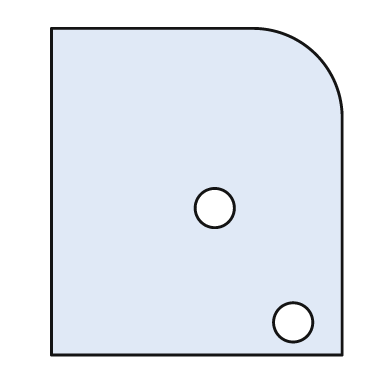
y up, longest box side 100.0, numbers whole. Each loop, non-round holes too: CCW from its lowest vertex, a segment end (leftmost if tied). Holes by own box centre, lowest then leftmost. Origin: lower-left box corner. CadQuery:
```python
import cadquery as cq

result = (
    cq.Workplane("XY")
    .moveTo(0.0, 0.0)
    .lineTo(89.0, 0.0)
    .lineTo(89.0, 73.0)
    .threePointArc((81.0, 92.0), (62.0, 100.0))
    .lineTo(0.0, 100.0)
    .close()
    .moveTo(74.0, 10.0)
    .circle(6.0)
    .moveTo(50.0, 45.0)
    .circle(6.0)
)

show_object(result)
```